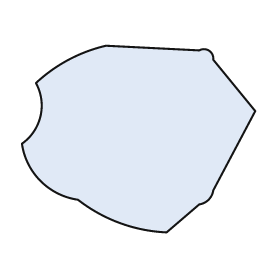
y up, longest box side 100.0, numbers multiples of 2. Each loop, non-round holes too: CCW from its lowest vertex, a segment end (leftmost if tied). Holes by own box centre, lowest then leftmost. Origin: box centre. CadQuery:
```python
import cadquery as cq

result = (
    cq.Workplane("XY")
    .moveTo(12.0, -40.0)
    .lineTo(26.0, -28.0)
    .threePointArc((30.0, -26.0), (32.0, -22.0))
    .lineTo(50.0, 12.0)
    .lineTo(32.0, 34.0)
    .threePointArc((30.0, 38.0), (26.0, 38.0))
    .lineTo(-14.0, 40.0)
    .threePointArc((-30.0, 34.0), (-44.0, 24.0))
    .threePointArc((-42.0, 10.0), (-50.0, -2.0))
    .threePointArc((-42.0, -18.0), (-26.0, -26.0))
    .threePointArc((-8.0, -36.0), (12.0, -40.0))
    .close()
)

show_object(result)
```